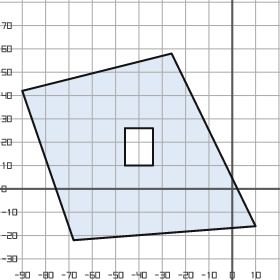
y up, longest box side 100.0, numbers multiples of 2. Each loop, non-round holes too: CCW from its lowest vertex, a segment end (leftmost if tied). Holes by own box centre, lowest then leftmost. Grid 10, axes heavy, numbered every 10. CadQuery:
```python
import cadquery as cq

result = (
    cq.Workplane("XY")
    .moveTo(-68.0, -22.0)
    .lineTo(10.0, -16.0)
    .lineTo(-26.0, 58.0)
    .lineTo(-90.0, 42.0)
    .close()
    .moveTo(-46.0, 10.0)
    .lineTo(-34.0, 10.0)
    .lineTo(-34.0, 26.0)
    .lineTo(-46.0, 26.0)
    .close()
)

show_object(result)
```